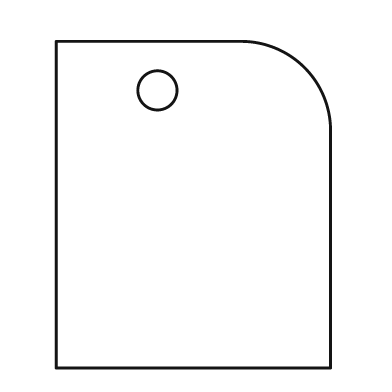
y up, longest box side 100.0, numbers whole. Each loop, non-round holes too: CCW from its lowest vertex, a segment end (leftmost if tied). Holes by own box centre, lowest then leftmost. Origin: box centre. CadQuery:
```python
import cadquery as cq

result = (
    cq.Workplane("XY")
    .moveTo(-42.0, -50.0)
    .lineTo(42.0, -50.0)
    .lineTo(42.0, 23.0)
    .threePointArc((34.0, 42.0), (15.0, 50.0))
    .lineTo(-42.0, 50.0)
    .close()
    .moveTo(-11.0, 35.0)
    .circle(6.0)
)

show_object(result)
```